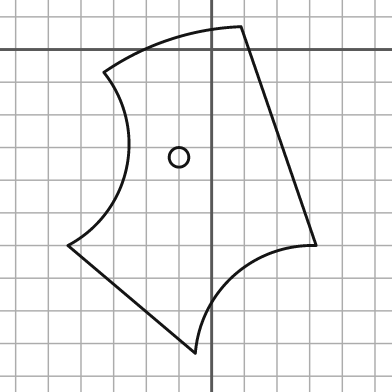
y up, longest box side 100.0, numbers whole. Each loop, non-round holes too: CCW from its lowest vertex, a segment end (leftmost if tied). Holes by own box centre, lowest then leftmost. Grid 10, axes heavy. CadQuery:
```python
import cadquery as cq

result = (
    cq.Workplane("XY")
    .moveTo(-5.0, -93.0)
    .threePointArc((7.0, -69.0), (32.0, -60.0))
    .lineTo(9.0, 7.0)
    .threePointArc((-13.0, 3.0), (-33.0, -7.0))
    .threePointArc((-26.0, -36.0), (-44.0, -60.0))
    .close()
    .moveTo(-10.0, -33.0)
    .circle(3.0)
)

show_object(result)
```